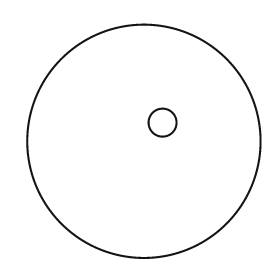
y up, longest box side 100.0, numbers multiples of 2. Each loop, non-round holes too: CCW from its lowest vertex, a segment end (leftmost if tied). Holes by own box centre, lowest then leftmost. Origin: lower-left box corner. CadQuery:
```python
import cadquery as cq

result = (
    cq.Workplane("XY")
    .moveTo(50.0, 50.0)
    .circle(50.0)
    .moveTo(58.0, 58.0)
    .circle(6.0)
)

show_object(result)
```